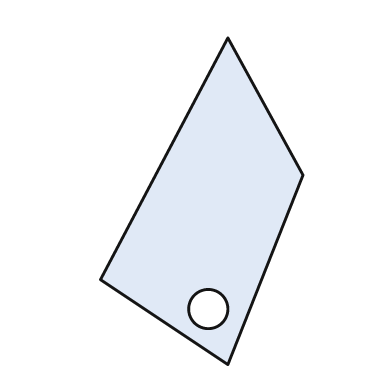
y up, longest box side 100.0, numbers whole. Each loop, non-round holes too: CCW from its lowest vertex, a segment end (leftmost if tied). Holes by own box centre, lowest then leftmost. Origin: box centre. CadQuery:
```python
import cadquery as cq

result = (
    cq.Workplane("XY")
    .moveTo(8.0, -50.0)
    .lineTo(31.0, 8.0)
    .lineTo(8.0, 50.0)
    .lineTo(-31.0, -24.0)
    .close()
    .moveTo(2.0, -33.0)
    .circle(6.0)
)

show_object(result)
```